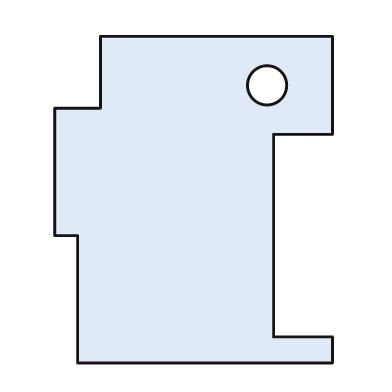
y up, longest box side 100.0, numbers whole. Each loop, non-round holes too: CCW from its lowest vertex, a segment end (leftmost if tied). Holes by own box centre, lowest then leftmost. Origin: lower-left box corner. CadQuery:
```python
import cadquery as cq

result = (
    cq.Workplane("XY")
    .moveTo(7.0, 0.0)
    .lineTo(85.0, 0.0)
    .lineTo(85.0, 8.0)
    .lineTo(67.0, 8.0)
    .lineTo(67.0, 70.0)
    .lineTo(85.0, 70.0)
    .lineTo(85.0, 100.0)
    .lineTo(14.0, 100.0)
    .lineTo(14.0, 78.0)
    .lineTo(0.0, 78.0)
    .lineTo(0.0, 39.0)
    .lineTo(7.0, 39.0)
    .close()
    .moveTo(65.0, 85.0)
    .circle(6.0)
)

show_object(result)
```